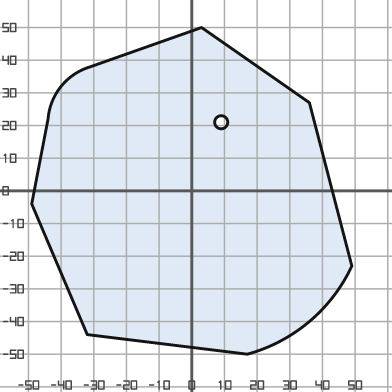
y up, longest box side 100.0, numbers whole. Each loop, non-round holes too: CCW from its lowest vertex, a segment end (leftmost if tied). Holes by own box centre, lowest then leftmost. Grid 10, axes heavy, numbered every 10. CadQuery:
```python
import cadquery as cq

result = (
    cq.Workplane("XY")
    .moveTo(17.0, -50.0)
    .threePointArc((36.0, -40.0), (49.0, -23.0))
    .lineTo(36.0, 27.0)
    .lineTo(3.0, 50.0)
    .lineTo(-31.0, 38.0)
    .threePointArc((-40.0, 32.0), (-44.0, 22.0))
    .lineTo(-49.0, -4.0)
    .lineTo(-32.0, -44.0)
    .close()
    .moveTo(9.0, 21.0)
    .circle(2.0)
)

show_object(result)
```